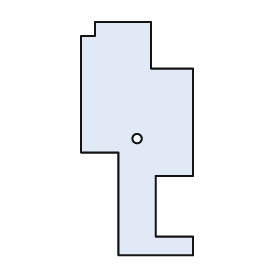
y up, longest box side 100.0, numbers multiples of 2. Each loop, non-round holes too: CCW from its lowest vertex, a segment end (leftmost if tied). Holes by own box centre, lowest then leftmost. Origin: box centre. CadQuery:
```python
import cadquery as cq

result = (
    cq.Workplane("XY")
    .moveTo(-8.0, -50.0)
    .lineTo(24.0, -50.0)
    .lineTo(24.0, -42.0)
    .lineTo(8.0, -42.0)
    .lineTo(8.0, -16.0)
    .lineTo(24.0, -16.0)
    .lineTo(24.0, 30.0)
    .lineTo(6.0, 30.0)
    .lineTo(6.0, 50.0)
    .lineTo(-18.0, 50.0)
    .lineTo(-18.0, 44.0)
    .lineTo(-24.0, 44.0)
    .lineTo(-24.0, -6.0)
    .lineTo(-8.0, -6.0)
    .close()
    .moveTo(0.0, 0.0)
    .circle(2.0)
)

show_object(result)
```